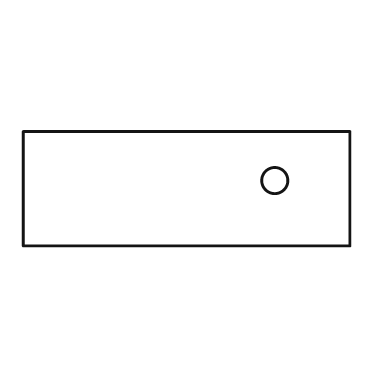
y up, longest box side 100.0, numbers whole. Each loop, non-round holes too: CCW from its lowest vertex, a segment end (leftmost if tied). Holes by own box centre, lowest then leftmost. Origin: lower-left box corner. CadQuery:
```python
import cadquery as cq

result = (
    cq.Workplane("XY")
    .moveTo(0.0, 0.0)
    .lineTo(100.0, 0.0)
    .lineTo(100.0, 35.0)
    .lineTo(0.0, 35.0)
    .close()
    .moveTo(77.0, 20.0)
    .circle(4.0)
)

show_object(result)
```